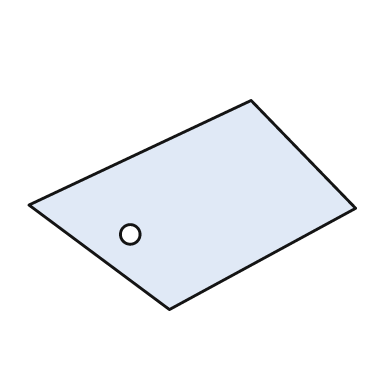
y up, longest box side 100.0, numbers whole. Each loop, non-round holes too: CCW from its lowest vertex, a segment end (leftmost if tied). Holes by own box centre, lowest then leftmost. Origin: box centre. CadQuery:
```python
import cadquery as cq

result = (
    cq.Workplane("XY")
    .moveTo(-7.0, -32.0)
    .lineTo(50.0, -1.0)
    .lineTo(18.0, 32.0)
    .lineTo(-50.0, 0.0)
    .close()
    .moveTo(-19.0, -9.0)
    .circle(3.0)
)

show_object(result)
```